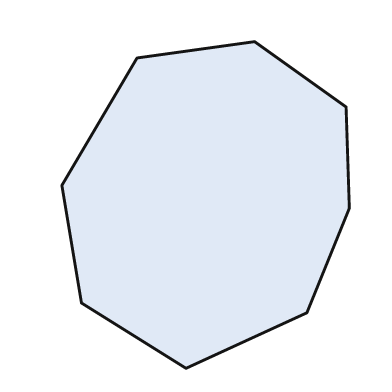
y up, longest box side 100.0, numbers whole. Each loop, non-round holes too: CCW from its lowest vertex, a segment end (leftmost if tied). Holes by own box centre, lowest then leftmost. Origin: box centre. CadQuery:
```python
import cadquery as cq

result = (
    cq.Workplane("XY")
    .moveTo(-6.0, -50.0)
    .lineTo(31.0, -33.0)
    .lineTo(44.0, -1.0)
    .lineTo(43.0, 30.0)
    .lineTo(15.0, 50.0)
    .lineTo(-21.0, 45.0)
    .lineTo(-44.0, 6.0)
    .lineTo(-38.0, -30.0)
    .close()
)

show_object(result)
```